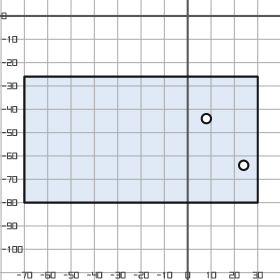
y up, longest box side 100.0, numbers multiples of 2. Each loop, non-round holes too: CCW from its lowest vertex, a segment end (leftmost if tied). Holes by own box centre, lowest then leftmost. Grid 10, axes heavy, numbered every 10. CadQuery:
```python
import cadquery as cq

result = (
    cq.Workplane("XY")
    .moveTo(-70.0, -80.0)
    .lineTo(30.0, -80.0)
    .lineTo(30.0, -26.0)
    .lineTo(-70.0, -26.0)
    .close()
    .moveTo(24.0, -64.0)
    .circle(2.0)
    .moveTo(8.0, -44.0)
    .circle(2.0)
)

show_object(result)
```